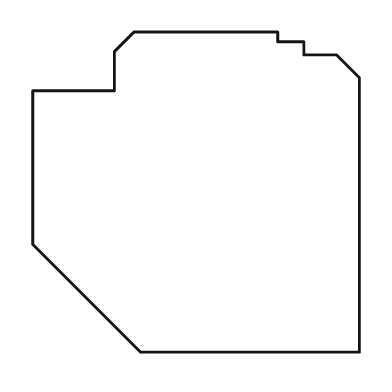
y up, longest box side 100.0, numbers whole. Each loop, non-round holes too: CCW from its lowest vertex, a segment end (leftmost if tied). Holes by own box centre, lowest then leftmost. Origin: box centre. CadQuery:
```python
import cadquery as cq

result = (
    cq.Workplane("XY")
    .moveTo(-17.0, -49.0)
    .lineTo(50.0, -49.0)
    .lineTo(50.0, 35.0)
    .lineTo(43.0, 42.0)
    .lineTo(33.0, 42.0)
    .lineTo(33.0, 46.0)
    .lineTo(25.0, 46.0)
    .lineTo(25.0, 49.0)
    .lineTo(-19.0, 49.0)
    .lineTo(-25.0, 43.0)
    .lineTo(-25.0, 31.0)
    .lineTo(-50.0, 31.0)
    .lineTo(-50.0, -16.0)
    .close()
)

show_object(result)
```